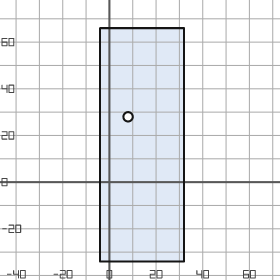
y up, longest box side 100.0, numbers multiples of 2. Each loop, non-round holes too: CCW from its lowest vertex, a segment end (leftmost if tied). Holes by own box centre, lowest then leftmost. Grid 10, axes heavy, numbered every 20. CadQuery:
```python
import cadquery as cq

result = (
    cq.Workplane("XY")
    .moveTo(-4.0, -34.0)
    .lineTo(32.0, -34.0)
    .lineTo(32.0, 66.0)
    .lineTo(-4.0, 66.0)
    .close()
    .moveTo(8.0, 28.0)
    .circle(2.0)
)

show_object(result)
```